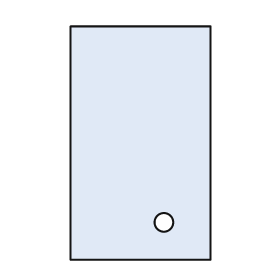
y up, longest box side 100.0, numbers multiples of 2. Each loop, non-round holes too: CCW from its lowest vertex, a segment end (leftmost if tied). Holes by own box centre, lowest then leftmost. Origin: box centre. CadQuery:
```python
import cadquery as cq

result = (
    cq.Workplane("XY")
    .moveTo(-30.0, -50.0)
    .lineTo(30.0, -50.0)
    .lineTo(30.0, 50.0)
    .lineTo(-30.0, 50.0)
    .close()
    .moveTo(10.0, -34.0)
    .circle(4.0)
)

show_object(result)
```